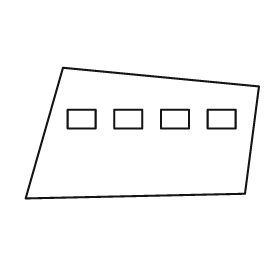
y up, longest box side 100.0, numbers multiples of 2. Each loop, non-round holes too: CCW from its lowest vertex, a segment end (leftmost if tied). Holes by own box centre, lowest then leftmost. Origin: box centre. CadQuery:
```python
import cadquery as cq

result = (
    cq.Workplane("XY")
    .moveTo(-50.0, -28.0)
    .lineTo(44.0, -26.0)
    .lineTo(50.0, 20.0)
    .lineTo(-34.0, 28.0)
    .close()
    .moveTo(-32.0, 2.0)
    .lineTo(-20.0, 2.0)
    .lineTo(-20.0, 10.0)
    .lineTo(-32.0, 10.0)
    .close()
    .moveTo(-12.0, 2.0)
    .lineTo(0.0, 2.0)
    .lineTo(0.0, 10.0)
    .lineTo(-12.0, 10.0)
    .close()
    .moveTo(8.0, 2.0)
    .lineTo(20.0, 2.0)
    .lineTo(20.0, 10.0)
    .lineTo(8.0, 10.0)
    .close()
    .moveTo(28.0, 2.0)
    .lineTo(40.0, 2.0)
    .lineTo(40.0, 10.0)
    .lineTo(28.0, 10.0)
    .close()
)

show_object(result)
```